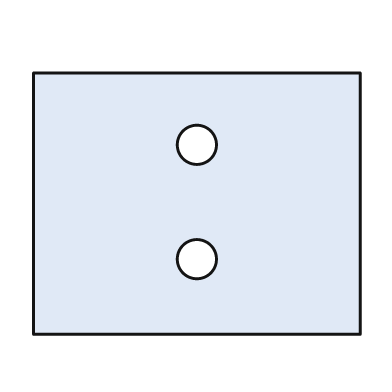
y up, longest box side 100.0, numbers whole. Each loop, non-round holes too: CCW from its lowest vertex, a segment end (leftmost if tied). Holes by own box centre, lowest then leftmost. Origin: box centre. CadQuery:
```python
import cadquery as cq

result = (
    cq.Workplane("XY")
    .moveTo(-50.0, -40.0)
    .lineTo(50.0, -40.0)
    .lineTo(50.0, 40.0)
    .lineTo(-50.0, 40.0)
    .close()
    .moveTo(0.0, -17.0)
    .circle(6.0)
    .moveTo(0.0, 18.0)
    .circle(6.0)
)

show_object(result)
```